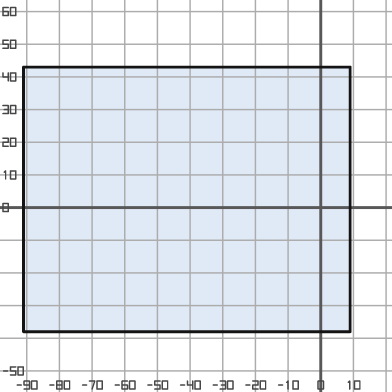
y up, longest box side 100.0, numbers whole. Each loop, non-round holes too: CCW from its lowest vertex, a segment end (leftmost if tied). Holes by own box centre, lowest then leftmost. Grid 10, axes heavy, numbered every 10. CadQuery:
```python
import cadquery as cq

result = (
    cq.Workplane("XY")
    .moveTo(-91.0, -38.0)
    .lineTo(9.0, -38.0)
    .lineTo(9.0, 43.0)
    .lineTo(-91.0, 43.0)
    .close()
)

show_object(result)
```